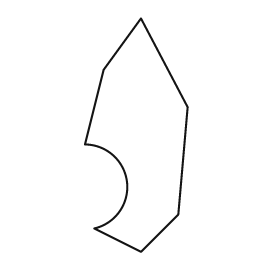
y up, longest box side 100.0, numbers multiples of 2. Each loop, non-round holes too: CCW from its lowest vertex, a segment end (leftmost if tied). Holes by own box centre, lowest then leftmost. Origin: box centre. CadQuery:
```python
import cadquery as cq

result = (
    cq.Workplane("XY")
    .moveTo(2.0, -50.0)
    .lineTo(18.0, -34.0)
    .lineTo(22.0, 12.0)
    .lineTo(2.0, 50.0)
    .lineTo(-14.0, 28.0)
    .lineTo(-22.0, -4.0)
    .threePointArc((-4.0, -20.0), (-18.0, -40.0))
    .close()
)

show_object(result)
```